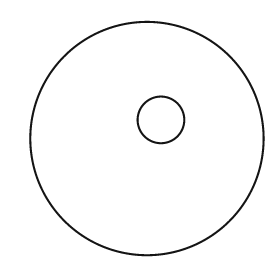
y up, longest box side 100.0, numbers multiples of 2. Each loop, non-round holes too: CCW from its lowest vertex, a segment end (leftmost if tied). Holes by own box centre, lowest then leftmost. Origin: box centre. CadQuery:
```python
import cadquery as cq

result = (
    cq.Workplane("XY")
    .moveTo(0.0, 0.0)
    .circle(50.0)
    .moveTo(6.0, 8.0)
    .circle(10.0)
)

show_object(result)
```